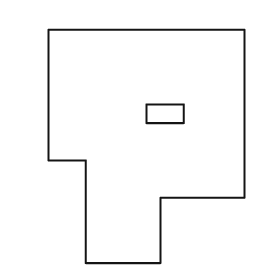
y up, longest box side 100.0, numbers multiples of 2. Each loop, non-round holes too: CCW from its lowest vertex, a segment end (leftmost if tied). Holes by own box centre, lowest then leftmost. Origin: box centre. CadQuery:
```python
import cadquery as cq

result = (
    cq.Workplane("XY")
    .moveTo(-26.0, -50.0)
    .lineTo(6.0, -50.0)
    .lineTo(6.0, -22.0)
    .lineTo(42.0, -22.0)
    .lineTo(42.0, 50.0)
    .lineTo(-42.0, 50.0)
    .lineTo(-42.0, -6.0)
    .lineTo(-26.0, -6.0)
    .close()
    .moveTo(0.0, 10.0)
    .lineTo(16.0, 10.0)
    .lineTo(16.0, 18.0)
    .lineTo(0.0, 18.0)
    .close()
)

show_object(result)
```